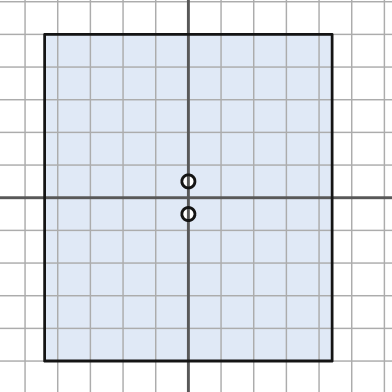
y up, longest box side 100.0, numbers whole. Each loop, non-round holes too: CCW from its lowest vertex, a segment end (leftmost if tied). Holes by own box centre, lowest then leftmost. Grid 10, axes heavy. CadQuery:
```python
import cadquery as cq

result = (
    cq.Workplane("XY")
    .moveTo(-44.0, -50.0)
    .lineTo(44.0, -50.0)
    .lineTo(44.0, 50.0)
    .lineTo(-44.0, 50.0)
    .close()
    .moveTo(0.0, -5.0)
    .circle(2.0)
    .moveTo(0.0, 5.0)
    .circle(2.0)
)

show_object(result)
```